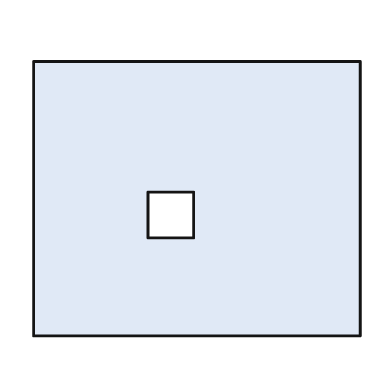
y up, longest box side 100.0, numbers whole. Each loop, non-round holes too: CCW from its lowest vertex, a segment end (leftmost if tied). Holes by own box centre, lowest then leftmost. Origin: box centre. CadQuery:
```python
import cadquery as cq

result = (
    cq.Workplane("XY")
    .moveTo(-50.0, -42.0)
    .lineTo(50.0, -42.0)
    .lineTo(50.0, 42.0)
    .lineTo(-50.0, 42.0)
    .close()
    .moveTo(-15.0, -12.0)
    .lineTo(-1.0, -12.0)
    .lineTo(-1.0, 2.0)
    .lineTo(-15.0, 2.0)
    .close()
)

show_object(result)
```